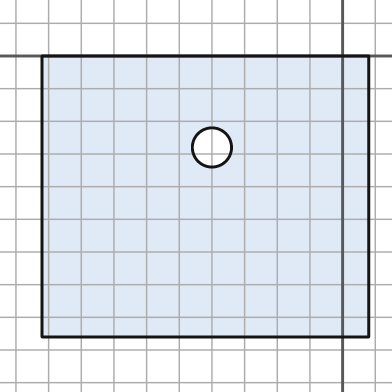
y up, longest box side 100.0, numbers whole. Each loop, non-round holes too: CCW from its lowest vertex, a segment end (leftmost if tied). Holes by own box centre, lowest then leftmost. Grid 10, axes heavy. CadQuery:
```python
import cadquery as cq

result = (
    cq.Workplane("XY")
    .moveTo(-92.0, -86.0)
    .lineTo(8.0, -86.0)
    .lineTo(8.0, 0.0)
    .lineTo(-92.0, 0.0)
    .close()
    .moveTo(-40.0, -28.0)
    .circle(6.0)
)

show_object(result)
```